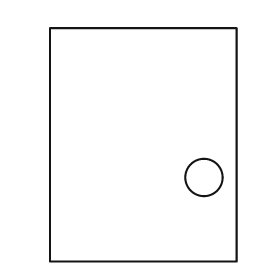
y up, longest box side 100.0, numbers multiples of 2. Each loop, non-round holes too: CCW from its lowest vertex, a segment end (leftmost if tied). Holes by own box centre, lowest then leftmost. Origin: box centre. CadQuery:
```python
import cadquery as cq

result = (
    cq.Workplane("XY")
    .moveTo(-40.0, -50.0)
    .lineTo(40.0, -50.0)
    .lineTo(40.0, 50.0)
    .lineTo(-40.0, 50.0)
    .close()
    .moveTo(26.0, -14.0)
    .circle(8.0)
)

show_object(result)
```